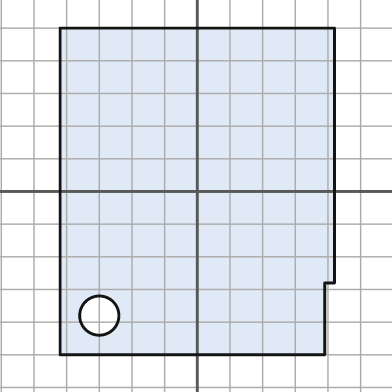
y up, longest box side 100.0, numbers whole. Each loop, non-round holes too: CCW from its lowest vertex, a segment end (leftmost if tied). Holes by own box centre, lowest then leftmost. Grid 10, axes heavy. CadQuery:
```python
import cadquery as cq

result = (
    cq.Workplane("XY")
    .moveTo(-42.0, -50.0)
    .lineTo(39.0, -50.0)
    .lineTo(39.0, -28.0)
    .lineTo(42.0, -28.0)
    .lineTo(42.0, 50.0)
    .lineTo(-42.0, 50.0)
    .close()
    .moveTo(-30.0, -38.0)
    .circle(6.0)
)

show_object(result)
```